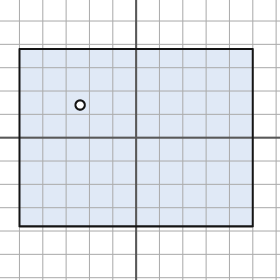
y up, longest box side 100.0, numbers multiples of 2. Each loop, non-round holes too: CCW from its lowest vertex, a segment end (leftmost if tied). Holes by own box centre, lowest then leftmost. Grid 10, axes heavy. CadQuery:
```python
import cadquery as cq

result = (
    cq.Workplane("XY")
    .moveTo(-50.0, -38.0)
    .lineTo(50.0, -38.0)
    .lineTo(50.0, 38.0)
    .lineTo(-50.0, 38.0)
    .close()
    .moveTo(-24.0, 14.0)
    .circle(2.0)
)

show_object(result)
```